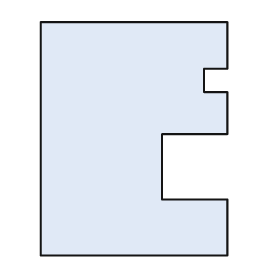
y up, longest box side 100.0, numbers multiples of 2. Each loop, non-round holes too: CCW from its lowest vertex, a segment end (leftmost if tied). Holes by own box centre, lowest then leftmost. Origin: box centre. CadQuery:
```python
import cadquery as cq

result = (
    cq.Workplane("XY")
    .moveTo(-40.0, -50.0)
    .lineTo(40.0, -50.0)
    .lineTo(40.0, -26.0)
    .lineTo(12.0, -26.0)
    .lineTo(12.0, 2.0)
    .lineTo(40.0, 2.0)
    .lineTo(40.0, 20.0)
    .lineTo(30.0, 20.0)
    .lineTo(30.0, 30.0)
    .lineTo(40.0, 30.0)
    .lineTo(40.0, 50.0)
    .lineTo(-40.0, 50.0)
    .close()
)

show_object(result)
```